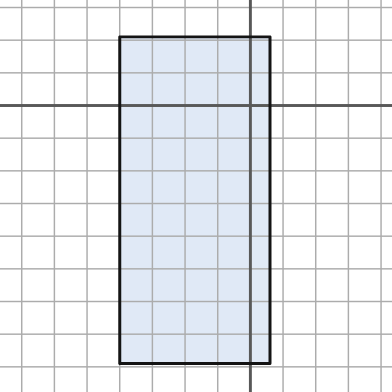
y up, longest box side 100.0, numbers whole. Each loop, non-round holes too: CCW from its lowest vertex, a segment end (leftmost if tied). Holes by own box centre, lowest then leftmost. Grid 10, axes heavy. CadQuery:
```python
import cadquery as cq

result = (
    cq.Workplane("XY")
    .moveTo(-40.0, -79.0)
    .lineTo(6.0, -79.0)
    .lineTo(6.0, 21.0)
    .lineTo(-40.0, 21.0)
    .close()
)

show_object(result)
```